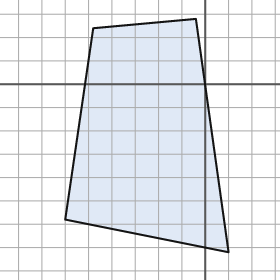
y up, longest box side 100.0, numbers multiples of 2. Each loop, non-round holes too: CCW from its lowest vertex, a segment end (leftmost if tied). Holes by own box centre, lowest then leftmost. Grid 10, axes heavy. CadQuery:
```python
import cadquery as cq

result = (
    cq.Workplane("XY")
    .moveTo(10.0, -72.0)
    .lineTo(-4.0, 28.0)
    .lineTo(-48.0, 24.0)
    .lineTo(-60.0, -58.0)
    .close()
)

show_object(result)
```